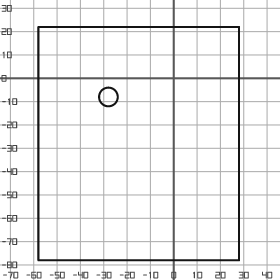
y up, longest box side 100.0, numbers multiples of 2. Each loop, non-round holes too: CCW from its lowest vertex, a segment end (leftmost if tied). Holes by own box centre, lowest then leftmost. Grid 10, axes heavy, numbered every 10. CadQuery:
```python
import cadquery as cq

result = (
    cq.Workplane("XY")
    .moveTo(-58.0, -78.0)
    .lineTo(28.0, -78.0)
    .lineTo(28.0, 22.0)
    .lineTo(-58.0, 22.0)
    .close()
    .moveTo(-28.0, -8.0)
    .circle(4.0)
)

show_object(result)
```